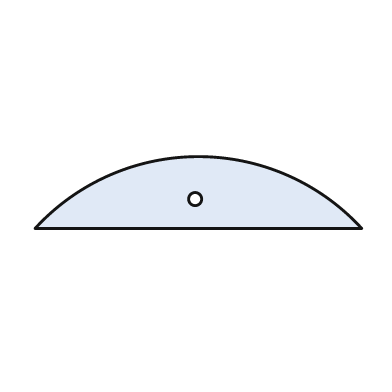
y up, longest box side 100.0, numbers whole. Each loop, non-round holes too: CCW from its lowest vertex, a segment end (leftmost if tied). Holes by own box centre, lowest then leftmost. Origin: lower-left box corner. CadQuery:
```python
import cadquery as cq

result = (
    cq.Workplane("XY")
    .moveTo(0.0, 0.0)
    .lineTo(100.0, 0.0)
    .threePointArc((50.0, 22.0), (0.0, 0.0))
    .close()
    .moveTo(49.0, 9.0)
    .circle(2.0)
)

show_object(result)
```